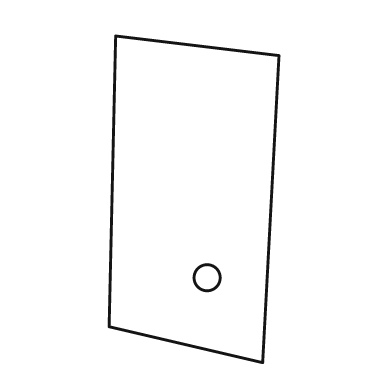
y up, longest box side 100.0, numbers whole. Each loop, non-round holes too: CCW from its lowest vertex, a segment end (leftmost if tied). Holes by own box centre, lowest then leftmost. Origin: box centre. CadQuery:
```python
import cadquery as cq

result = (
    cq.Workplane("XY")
    .moveTo(21.0, -50.0)
    .lineTo(26.0, 44.0)
    .lineTo(-24.0, 50.0)
    .lineTo(-26.0, -39.0)
    .close()
    .moveTo(4.0, -24.0)
    .circle(4.0)
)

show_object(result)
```